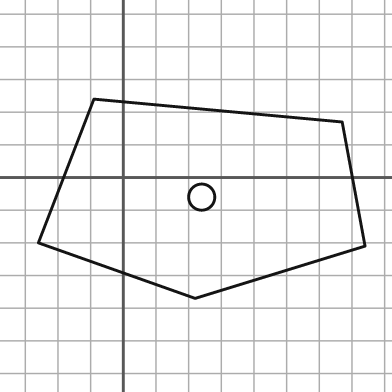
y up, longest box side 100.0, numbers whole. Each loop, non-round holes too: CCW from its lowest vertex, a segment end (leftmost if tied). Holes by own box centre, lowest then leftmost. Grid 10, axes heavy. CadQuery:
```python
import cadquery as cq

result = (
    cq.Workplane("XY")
    .moveTo(22.0, -37.0)
    .lineTo(74.0, -21.0)
    .lineTo(67.0, 17.0)
    .lineTo(-9.0, 24.0)
    .lineTo(-26.0, -20.0)
    .close()
    .moveTo(24.0, -6.0)
    .circle(4.0)
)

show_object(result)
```